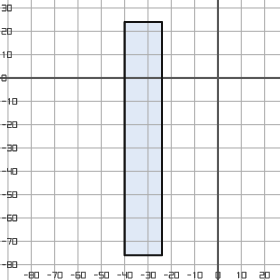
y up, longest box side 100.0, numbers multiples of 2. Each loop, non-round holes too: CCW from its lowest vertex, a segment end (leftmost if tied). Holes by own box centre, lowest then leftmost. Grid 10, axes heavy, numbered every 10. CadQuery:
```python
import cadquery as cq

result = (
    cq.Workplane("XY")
    .moveTo(-40.0, -76.0)
    .lineTo(-24.0, -76.0)
    .lineTo(-24.0, 24.0)
    .lineTo(-40.0, 24.0)
    .close()
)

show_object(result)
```